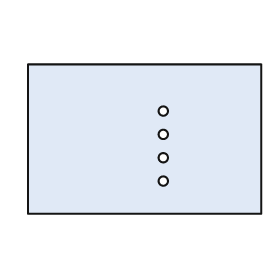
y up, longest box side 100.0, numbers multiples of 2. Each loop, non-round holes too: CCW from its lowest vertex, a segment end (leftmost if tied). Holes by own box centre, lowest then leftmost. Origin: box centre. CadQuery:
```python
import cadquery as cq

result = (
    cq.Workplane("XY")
    .moveTo(-50.0, -32.0)
    .lineTo(50.0, -32.0)
    .lineTo(50.0, 32.0)
    .lineTo(-50.0, 32.0)
    .close()
    .moveTo(8.0, -18.0)
    .circle(2.0)
    .moveTo(8.0, -8.0)
    .circle(2.0)
    .moveTo(8.0, 2.0)
    .circle(2.0)
    .moveTo(8.0, 12.0)
    .circle(2.0)
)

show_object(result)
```